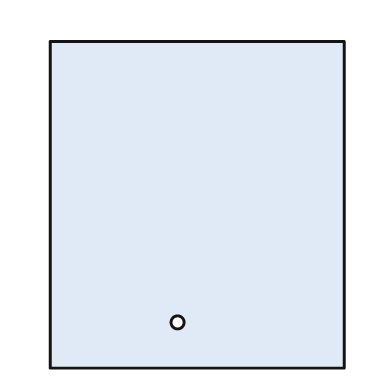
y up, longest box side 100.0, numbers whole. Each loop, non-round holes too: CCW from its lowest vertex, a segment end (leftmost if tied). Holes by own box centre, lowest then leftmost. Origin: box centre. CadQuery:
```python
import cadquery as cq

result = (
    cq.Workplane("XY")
    .moveTo(-45.0, -50.0)
    .lineTo(45.0, -50.0)
    .lineTo(45.0, 50.0)
    .lineTo(-45.0, 50.0)
    .close()
    .moveTo(-6.0, -36.0)
    .circle(2.0)
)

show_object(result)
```